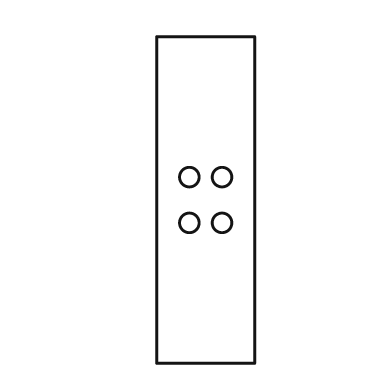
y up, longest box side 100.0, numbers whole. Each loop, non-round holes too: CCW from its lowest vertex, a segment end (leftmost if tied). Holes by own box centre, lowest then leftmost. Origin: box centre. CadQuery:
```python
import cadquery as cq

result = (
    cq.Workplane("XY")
    .moveTo(-15.0, -50.0)
    .lineTo(15.0, -50.0)
    .lineTo(15.0, 50.0)
    .lineTo(-15.0, 50.0)
    .close()
    .moveTo(-5.0, -7.0)
    .circle(3.0)
    .moveTo(5.0, -7.0)
    .circle(3.0)
    .moveTo(-5.0, 7.0)
    .circle(3.0)
    .moveTo(5.0, 7.0)
    .circle(3.0)
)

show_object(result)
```